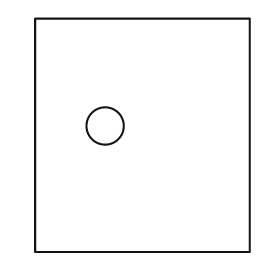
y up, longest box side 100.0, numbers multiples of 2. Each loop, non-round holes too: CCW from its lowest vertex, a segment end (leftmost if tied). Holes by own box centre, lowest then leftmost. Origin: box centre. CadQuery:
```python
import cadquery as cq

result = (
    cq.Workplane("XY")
    .moveTo(-46.0, -50.0)
    .lineTo(46.0, -50.0)
    .lineTo(46.0, 50.0)
    .lineTo(-46.0, 50.0)
    .close()
    .moveTo(-16.0, 4.0)
    .circle(8.0)
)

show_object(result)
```